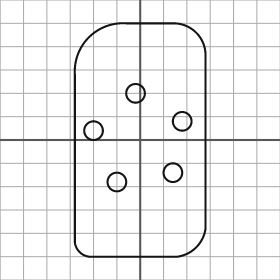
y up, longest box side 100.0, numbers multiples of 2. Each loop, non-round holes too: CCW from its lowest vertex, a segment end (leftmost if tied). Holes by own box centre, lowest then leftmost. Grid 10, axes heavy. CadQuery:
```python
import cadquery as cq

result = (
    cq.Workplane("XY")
    .moveTo(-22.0, -50.0)
    .lineTo(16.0, -50.0)
    .threePointArc((24.0, -46.0), (28.0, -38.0))
    .lineTo(28.0, 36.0)
    .threePointArc((24.0, 46.0), (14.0, 50.0))
    .lineTo(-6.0, 50.0)
    .threePointArc((-22.0, 44.0), (-28.0, 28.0))
    .lineTo(-28.0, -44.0)
    .threePointArc((-26.0, -48.0), (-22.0, -50.0))
    .close()
    .moveTo(-10.0, -18.0)
    .circle(4.0)
    .moveTo(14.0, -14.0)
    .circle(4.0)
    .moveTo(-20.0, 4.0)
    .circle(4.0)
    .moveTo(18.0, 8.0)
    .circle(4.0)
    .moveTo(-2.0, 20.0)
    .circle(4.0)
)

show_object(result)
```